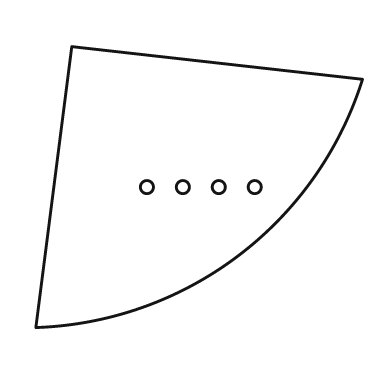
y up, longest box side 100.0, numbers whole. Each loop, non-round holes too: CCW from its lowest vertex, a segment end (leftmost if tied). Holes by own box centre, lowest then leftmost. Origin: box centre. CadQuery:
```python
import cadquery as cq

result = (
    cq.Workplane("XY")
    .moveTo(-50.0, -43.0)
    .threePointArc((12.0, -21.0), (50.0, 33.0))
    .lineTo(-39.0, 43.0)
    .close()
    .moveTo(-16.0, 0.0)
    .circle(2.0)
    .moveTo(-5.0, 0.0)
    .circle(2.0)
    .moveTo(6.0, 0.0)
    .circle(2.0)
    .moveTo(17.0, 0.0)
    .circle(2.0)
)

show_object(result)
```